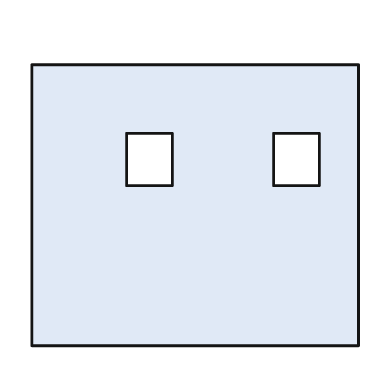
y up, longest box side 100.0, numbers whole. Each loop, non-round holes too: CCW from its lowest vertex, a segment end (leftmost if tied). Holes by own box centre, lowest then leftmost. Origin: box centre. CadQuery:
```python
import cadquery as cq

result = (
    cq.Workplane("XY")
    .moveTo(-50.0, -43.0)
    .lineTo(50.0, -43.0)
    .lineTo(50.0, 43.0)
    .lineTo(-50.0, 43.0)
    .close()
    .moveTo(-21.0, 6.0)
    .lineTo(-7.0, 6.0)
    .lineTo(-7.0, 22.0)
    .lineTo(-21.0, 22.0)
    .close()
    .moveTo(24.0, 6.0)
    .lineTo(38.0, 6.0)
    .lineTo(38.0, 22.0)
    .lineTo(24.0, 22.0)
    .close()
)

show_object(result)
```